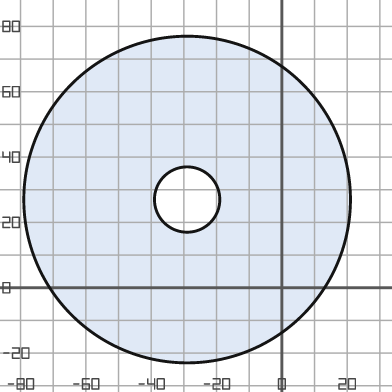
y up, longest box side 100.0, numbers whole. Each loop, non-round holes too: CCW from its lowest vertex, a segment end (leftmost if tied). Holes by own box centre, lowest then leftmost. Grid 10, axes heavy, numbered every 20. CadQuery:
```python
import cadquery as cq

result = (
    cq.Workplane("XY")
    .moveTo(-29.0, 27.0)
    .circle(50.0)
    .moveTo(-29.0, 27.0)
    .circle(10.0)
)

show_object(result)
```